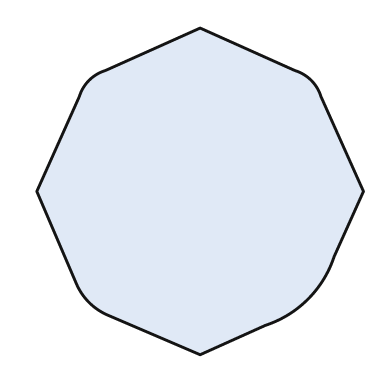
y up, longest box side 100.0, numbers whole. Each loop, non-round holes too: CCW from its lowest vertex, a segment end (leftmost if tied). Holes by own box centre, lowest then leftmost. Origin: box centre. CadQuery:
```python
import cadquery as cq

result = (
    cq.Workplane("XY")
    .moveTo(0.0, -50.0)
    .lineTo(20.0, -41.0)
    .threePointArc((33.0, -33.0), (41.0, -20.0))
    .lineTo(50.0, 0.0)
    .lineTo(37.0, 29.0)
    .threePointArc((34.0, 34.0), (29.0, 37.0))
    .lineTo(0.0, 50.0)
    .lineTo(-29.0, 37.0)
    .threePointArc((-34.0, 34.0), (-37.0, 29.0))
    .lineTo(-50.0, 0.0)
    .lineTo(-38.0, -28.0)
    .threePointArc((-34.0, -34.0), (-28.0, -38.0))
    .close()
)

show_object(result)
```